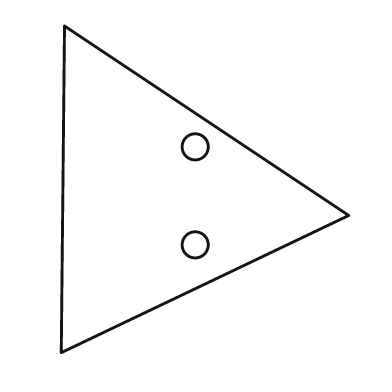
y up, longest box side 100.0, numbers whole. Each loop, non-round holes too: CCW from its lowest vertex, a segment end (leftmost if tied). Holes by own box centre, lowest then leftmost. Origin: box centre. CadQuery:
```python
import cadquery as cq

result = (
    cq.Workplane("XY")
    .moveTo(-44.0, -50.0)
    .lineTo(44.0, -8.0)
    .lineTo(-43.0, 50.0)
    .close()
    .moveTo(-3.0, -17.0)
    .circle(4.0)
    .moveTo(-3.0, 13.0)
    .circle(4.0)
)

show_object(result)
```